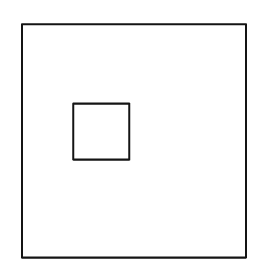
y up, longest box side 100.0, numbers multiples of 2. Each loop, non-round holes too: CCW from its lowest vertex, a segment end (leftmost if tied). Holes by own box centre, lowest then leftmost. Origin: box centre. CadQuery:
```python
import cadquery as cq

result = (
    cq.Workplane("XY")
    .moveTo(-48.0, -50.0)
    .lineTo(48.0, -50.0)
    .lineTo(48.0, 50.0)
    .lineTo(-48.0, 50.0)
    .close()
    .moveTo(-26.0, -8.0)
    .lineTo(-2.0, -8.0)
    .lineTo(-2.0, 16.0)
    .lineTo(-26.0, 16.0)
    .close()
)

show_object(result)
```